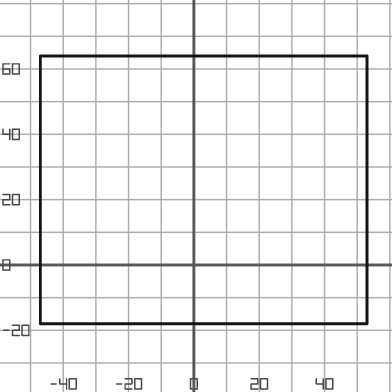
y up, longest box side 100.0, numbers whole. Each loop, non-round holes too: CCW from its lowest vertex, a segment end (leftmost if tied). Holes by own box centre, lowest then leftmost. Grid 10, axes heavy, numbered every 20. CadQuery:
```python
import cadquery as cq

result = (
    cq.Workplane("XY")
    .moveTo(-47.0, -18.0)
    .lineTo(53.0, -18.0)
    .lineTo(53.0, 64.0)
    .lineTo(-47.0, 64.0)
    .close()
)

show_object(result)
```